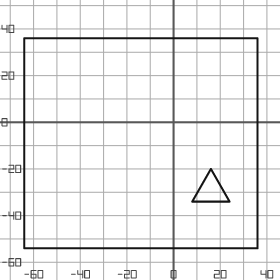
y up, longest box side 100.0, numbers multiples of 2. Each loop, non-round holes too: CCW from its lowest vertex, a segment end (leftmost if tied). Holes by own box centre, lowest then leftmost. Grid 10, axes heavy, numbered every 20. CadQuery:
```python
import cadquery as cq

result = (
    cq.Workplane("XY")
    .moveTo(-64.0, -54.0)
    .lineTo(36.0, -54.0)
    .lineTo(36.0, 36.0)
    .lineTo(-64.0, 36.0)
    .close()
    .moveTo(8.0, -34.0)
    .lineTo(24.0, -34.0)
    .lineTo(16.0, -20.0)
    .close()
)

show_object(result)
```